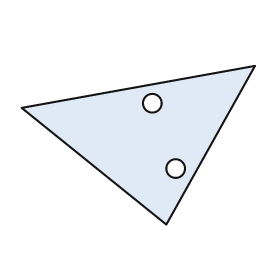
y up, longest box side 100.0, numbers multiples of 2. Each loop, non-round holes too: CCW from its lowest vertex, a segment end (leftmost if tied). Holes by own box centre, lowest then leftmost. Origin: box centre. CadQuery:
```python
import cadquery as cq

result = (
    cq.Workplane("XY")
    .moveTo(12.0, -34.0)
    .lineTo(50.0, 34.0)
    .lineTo(-50.0, 16.0)
    .close()
    .moveTo(16.0, -10.0)
    .circle(4.0)
    .moveTo(6.0, 18.0)
    .circle(4.0)
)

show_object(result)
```